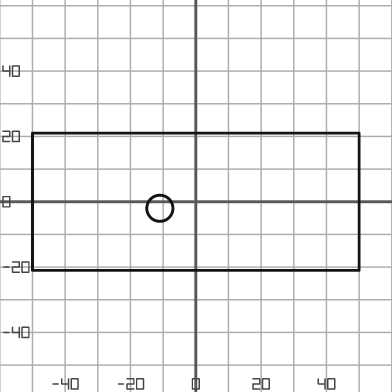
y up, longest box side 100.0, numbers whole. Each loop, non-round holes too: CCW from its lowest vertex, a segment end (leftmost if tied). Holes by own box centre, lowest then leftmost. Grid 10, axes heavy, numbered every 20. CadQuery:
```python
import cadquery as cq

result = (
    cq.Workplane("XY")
    .moveTo(-50.0, -21.0)
    .lineTo(50.0, -21.0)
    .lineTo(50.0, 21.0)
    .lineTo(-50.0, 21.0)
    .close()
    .moveTo(-11.0, -2.0)
    .circle(4.0)
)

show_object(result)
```